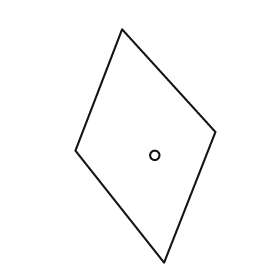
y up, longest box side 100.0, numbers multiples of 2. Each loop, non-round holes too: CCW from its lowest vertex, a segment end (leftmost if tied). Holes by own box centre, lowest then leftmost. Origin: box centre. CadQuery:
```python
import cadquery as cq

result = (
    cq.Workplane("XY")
    .moveTo(8.0, -50.0)
    .lineTo(30.0, 6.0)
    .lineTo(-10.0, 50.0)
    .lineTo(-30.0, -2.0)
    .close()
    .moveTo(4.0, -4.0)
    .circle(2.0)
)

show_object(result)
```